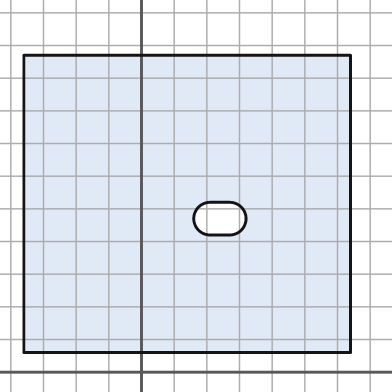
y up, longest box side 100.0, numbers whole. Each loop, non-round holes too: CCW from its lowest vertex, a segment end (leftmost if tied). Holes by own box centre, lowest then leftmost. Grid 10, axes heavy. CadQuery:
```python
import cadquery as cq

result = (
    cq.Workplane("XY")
    .moveTo(-36.0, 6.0)
    .lineTo(64.0, 6.0)
    .lineTo(64.0, 97.0)
    .lineTo(-36.0, 97.0)
    .close()
    .moveTo(21.0, 42.0)
    .lineTo(27.0, 42.0)
    .threePointArc((32.0, 47.0), (27.0, 52.0))
    .lineTo(21.0, 52.0)
    .threePointArc((16.0, 47.0), (21.0, 42.0))
    .close()
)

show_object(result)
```